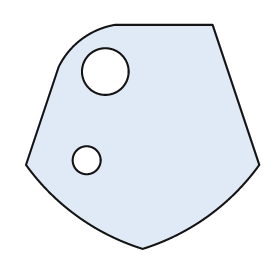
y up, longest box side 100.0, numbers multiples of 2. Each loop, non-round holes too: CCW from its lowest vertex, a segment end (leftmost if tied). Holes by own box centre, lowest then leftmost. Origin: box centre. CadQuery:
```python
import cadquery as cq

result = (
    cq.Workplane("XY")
    .moveTo(0.0, -48.0)
    .threePointArc((28.0, -34.0), (50.0, -12.0))
    .lineTo(30.0, 48.0)
    .lineTo(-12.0, 48.0)
    .threePointArc((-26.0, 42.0), (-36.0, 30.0))
    .lineTo(-50.0, -12.0)
    .threePointArc((-28.0, -34.0), (0.0, -48.0))
    .close()
    .moveTo(-24.0, -10.0)
    .circle(6.0)
    .moveTo(-16.0, 28.0)
    .circle(10.0)
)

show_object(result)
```